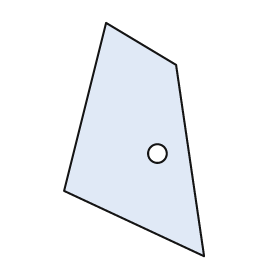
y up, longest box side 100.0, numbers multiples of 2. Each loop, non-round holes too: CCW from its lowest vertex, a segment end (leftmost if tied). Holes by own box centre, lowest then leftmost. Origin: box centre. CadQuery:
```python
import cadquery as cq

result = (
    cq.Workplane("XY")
    .moveTo(30.0, -50.0)
    .lineTo(18.0, 32.0)
    .lineTo(-12.0, 50.0)
    .lineTo(-30.0, -22.0)
    .close()
    .moveTo(10.0, -6.0)
    .circle(4.0)
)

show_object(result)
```